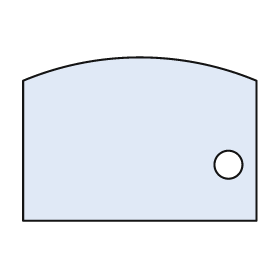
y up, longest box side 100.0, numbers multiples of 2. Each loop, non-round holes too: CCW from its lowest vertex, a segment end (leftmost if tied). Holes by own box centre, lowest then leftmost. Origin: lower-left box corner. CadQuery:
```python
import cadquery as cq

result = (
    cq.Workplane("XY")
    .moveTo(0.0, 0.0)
    .lineTo(100.0, 0.0)
    .lineTo(100.0, 60.0)
    .threePointArc((50.0, 70.0), (0.0, 60.0))
    .close()
    .moveTo(88.0, 24.0)
    .circle(6.0)
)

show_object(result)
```